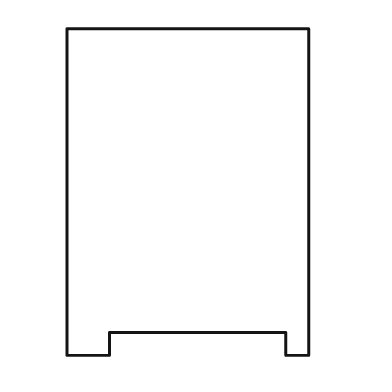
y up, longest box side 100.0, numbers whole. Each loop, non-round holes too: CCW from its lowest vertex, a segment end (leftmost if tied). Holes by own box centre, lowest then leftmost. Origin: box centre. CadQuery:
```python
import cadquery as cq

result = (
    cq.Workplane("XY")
    .moveTo(-37.0, -50.0)
    .lineTo(-24.0, -50.0)
    .lineTo(-24.0, -43.0)
    .lineTo(30.0, -43.0)
    .lineTo(30.0, -50.0)
    .lineTo(37.0, -50.0)
    .lineTo(37.0, 50.0)
    .lineTo(-37.0, 50.0)
    .close()
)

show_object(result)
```